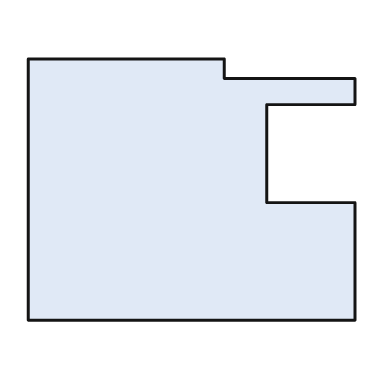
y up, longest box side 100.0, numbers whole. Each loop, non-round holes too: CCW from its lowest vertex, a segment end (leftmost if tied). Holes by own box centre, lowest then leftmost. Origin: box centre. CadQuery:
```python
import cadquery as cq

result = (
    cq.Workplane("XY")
    .moveTo(-50.0, -40.0)
    .lineTo(50.0, -40.0)
    .lineTo(50.0, -4.0)
    .lineTo(23.0, -4.0)
    .lineTo(23.0, 26.0)
    .lineTo(50.0, 26.0)
    .lineTo(50.0, 34.0)
    .lineTo(10.0, 34.0)
    .lineTo(10.0, 40.0)
    .lineTo(-50.0, 40.0)
    .close()
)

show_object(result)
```